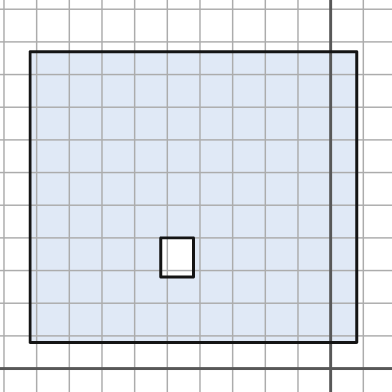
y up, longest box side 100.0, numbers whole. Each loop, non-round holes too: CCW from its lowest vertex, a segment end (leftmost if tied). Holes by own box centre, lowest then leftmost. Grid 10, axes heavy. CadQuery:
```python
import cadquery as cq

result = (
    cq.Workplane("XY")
    .moveTo(-92.0, 8.0)
    .lineTo(8.0, 8.0)
    .lineTo(8.0, 97.0)
    .lineTo(-92.0, 97.0)
    .close()
    .moveTo(-52.0, 28.0)
    .lineTo(-42.0, 28.0)
    .lineTo(-42.0, 40.0)
    .lineTo(-52.0, 40.0)
    .close()
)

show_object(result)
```